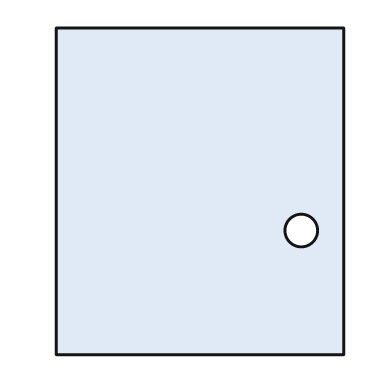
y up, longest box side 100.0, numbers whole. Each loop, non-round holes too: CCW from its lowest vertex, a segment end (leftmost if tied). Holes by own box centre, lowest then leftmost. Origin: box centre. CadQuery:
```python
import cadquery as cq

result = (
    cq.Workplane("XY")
    .moveTo(-44.0, -50.0)
    .lineTo(44.0, -50.0)
    .lineTo(44.0, 50.0)
    .lineTo(-44.0, 50.0)
    .close()
    .moveTo(31.0, -12.0)
    .circle(5.0)
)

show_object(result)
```